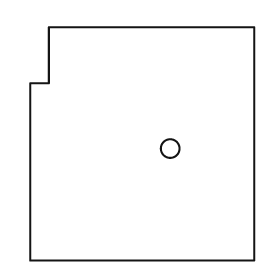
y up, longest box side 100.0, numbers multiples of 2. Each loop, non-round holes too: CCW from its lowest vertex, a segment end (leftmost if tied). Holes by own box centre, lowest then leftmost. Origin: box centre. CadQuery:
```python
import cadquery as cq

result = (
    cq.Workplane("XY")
    .moveTo(-48.0, -50.0)
    .lineTo(48.0, -50.0)
    .lineTo(48.0, 50.0)
    .lineTo(-40.0, 50.0)
    .lineTo(-40.0, 26.0)
    .lineTo(-48.0, 26.0)
    .close()
    .moveTo(12.0, -2.0)
    .circle(4.0)
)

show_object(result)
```